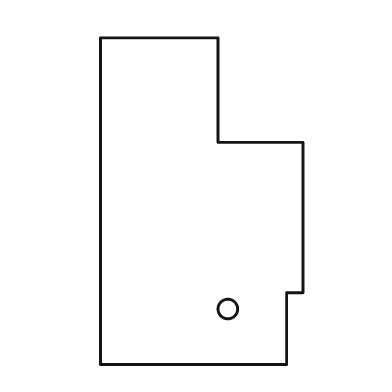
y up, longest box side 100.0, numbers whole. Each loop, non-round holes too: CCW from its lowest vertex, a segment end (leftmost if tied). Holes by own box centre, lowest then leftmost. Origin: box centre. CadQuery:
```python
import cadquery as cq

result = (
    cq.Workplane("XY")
    .moveTo(-31.0, -50.0)
    .lineTo(26.0, -50.0)
    .lineTo(26.0, -28.0)
    .lineTo(31.0, -28.0)
    .lineTo(31.0, 18.0)
    .lineTo(5.0, 18.0)
    .lineTo(5.0, 50.0)
    .lineTo(-31.0, 50.0)
    .close()
    .moveTo(8.0, -33.0)
    .circle(3.0)
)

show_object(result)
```